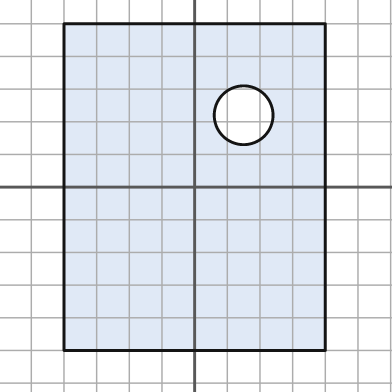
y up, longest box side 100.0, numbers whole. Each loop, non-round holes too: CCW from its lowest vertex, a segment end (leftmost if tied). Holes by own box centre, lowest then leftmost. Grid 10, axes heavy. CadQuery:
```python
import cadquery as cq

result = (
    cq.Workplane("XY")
    .moveTo(-40.0, -50.0)
    .lineTo(40.0, -50.0)
    .lineTo(40.0, 50.0)
    .lineTo(-40.0, 50.0)
    .close()
    .moveTo(15.0, 22.0)
    .circle(9.0)
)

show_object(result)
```